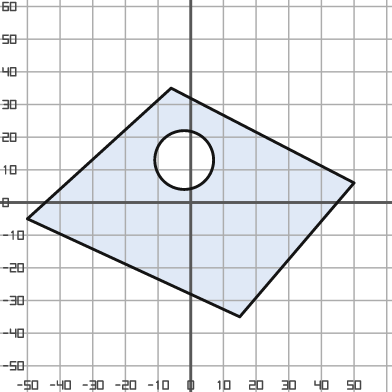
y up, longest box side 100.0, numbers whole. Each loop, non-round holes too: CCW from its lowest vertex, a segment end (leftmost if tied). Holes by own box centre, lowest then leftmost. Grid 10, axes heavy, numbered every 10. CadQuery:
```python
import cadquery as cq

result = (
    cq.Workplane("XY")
    .moveTo(15.0, -35.0)
    .lineTo(50.0, 6.0)
    .lineTo(-6.0, 35.0)
    .lineTo(-50.0, -5.0)
    .close()
    .moveTo(-2.0, 13.0)
    .circle(9.0)
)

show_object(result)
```